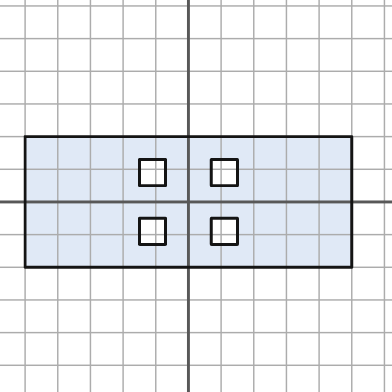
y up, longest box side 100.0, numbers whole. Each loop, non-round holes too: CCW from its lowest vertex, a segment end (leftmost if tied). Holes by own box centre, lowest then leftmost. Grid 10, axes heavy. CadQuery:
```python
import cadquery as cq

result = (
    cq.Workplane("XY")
    .moveTo(-50.0, -20.0)
    .lineTo(50.0, -20.0)
    .lineTo(50.0, 20.0)
    .lineTo(-50.0, 20.0)
    .close()
    .moveTo(-15.0, -13.0)
    .lineTo(-7.0, -13.0)
    .lineTo(-7.0, -5.0)
    .lineTo(-15.0, -5.0)
    .close()
    .moveTo(7.0, -13.0)
    .lineTo(15.0, -13.0)
    .lineTo(15.0, -5.0)
    .lineTo(7.0, -5.0)
    .close()
    .moveTo(-15.0, 5.0)
    .lineTo(-7.0, 5.0)
    .lineTo(-7.0, 13.0)
    .lineTo(-15.0, 13.0)
    .close()
    .moveTo(7.0, 5.0)
    .lineTo(15.0, 5.0)
    .lineTo(15.0, 13.0)
    .lineTo(7.0, 13.0)
    .close()
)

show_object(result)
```